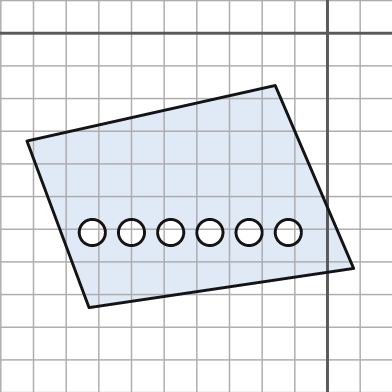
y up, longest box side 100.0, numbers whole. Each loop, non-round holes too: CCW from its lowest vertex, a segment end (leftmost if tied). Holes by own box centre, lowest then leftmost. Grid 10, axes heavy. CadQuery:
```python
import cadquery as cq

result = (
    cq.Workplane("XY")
    .moveTo(-73.0, -84.0)
    .lineTo(8.0, -72.0)
    .lineTo(-16.0, -16.0)
    .lineTo(-92.0, -33.0)
    .close()
    .moveTo(-72.0, -61.0)
    .circle(4.0)
    .moveTo(-60.0, -61.0)
    .circle(4.0)
    .moveTo(-48.0, -61.0)
    .circle(4.0)
    .moveTo(-36.0, -61.0)
    .circle(4.0)
    .moveTo(-24.0, -61.0)
    .circle(4.0)
    .moveTo(-12.0, -61.0)
    .circle(4.0)
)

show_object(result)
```